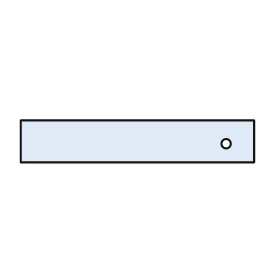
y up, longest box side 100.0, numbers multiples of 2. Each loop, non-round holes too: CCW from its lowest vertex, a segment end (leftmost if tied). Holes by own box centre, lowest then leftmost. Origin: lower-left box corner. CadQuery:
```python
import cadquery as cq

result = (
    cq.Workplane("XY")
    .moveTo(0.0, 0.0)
    .lineTo(100.0, 0.0)
    .lineTo(100.0, 18.0)
    .lineTo(0.0, 18.0)
    .close()
    .moveTo(88.0, 8.0)
    .circle(2.0)
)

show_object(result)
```